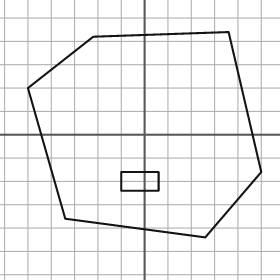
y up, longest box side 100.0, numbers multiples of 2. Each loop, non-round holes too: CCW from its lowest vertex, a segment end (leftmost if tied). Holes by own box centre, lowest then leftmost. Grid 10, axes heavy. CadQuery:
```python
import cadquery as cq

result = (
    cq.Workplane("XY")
    .moveTo(26.0, -44.0)
    .lineTo(50.0, -16.0)
    .lineTo(36.0, 44.0)
    .lineTo(-22.0, 42.0)
    .lineTo(-50.0, 20.0)
    .lineTo(-34.0, -36.0)
    .close()
    .moveTo(-10.0, -24.0)
    .lineTo(6.0, -24.0)
    .lineTo(6.0, -16.0)
    .lineTo(-10.0, -16.0)
    .close()
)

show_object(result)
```